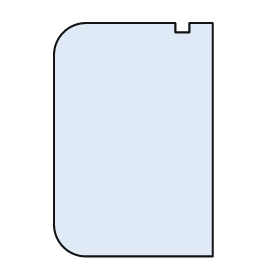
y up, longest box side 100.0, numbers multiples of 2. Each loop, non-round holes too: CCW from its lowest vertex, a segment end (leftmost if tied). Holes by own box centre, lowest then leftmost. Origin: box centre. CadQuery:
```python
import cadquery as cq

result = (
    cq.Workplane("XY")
    .moveTo(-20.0, -50.0)
    .lineTo(34.0, -50.0)
    .lineTo(34.0, 50.0)
    .lineTo(24.0, 50.0)
    .lineTo(24.0, 46.0)
    .lineTo(18.0, 46.0)
    .lineTo(18.0, 50.0)
    .lineTo(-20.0, 50.0)
    .threePointArc((-30.0, 46.0), (-34.0, 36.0))
    .lineTo(-34.0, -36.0)
    .threePointArc((-30.0, -46.0), (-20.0, -50.0))
    .close()
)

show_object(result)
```